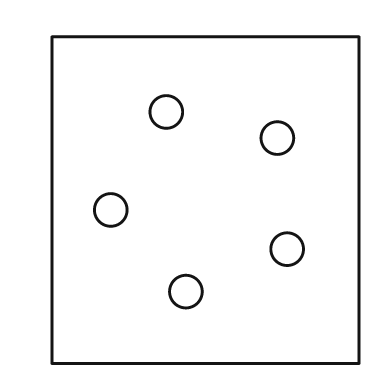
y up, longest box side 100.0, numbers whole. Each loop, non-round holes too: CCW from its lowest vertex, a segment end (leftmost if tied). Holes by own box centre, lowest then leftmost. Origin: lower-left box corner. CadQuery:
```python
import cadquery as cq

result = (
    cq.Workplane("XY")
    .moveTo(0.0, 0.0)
    .lineTo(94.0, 0.0)
    .lineTo(94.0, 100.0)
    .lineTo(0.0, 100.0)
    .close()
    .moveTo(41.0, 22.0)
    .circle(5.0)
    .moveTo(72.0, 35.0)
    .circle(5.0)
    .moveTo(18.0, 47.0)
    .circle(5.0)
    .moveTo(69.0, 69.0)
    .circle(5.0)
    .moveTo(35.0, 77.0)
    .circle(5.0)
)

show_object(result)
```